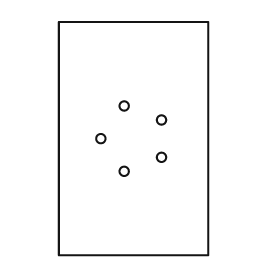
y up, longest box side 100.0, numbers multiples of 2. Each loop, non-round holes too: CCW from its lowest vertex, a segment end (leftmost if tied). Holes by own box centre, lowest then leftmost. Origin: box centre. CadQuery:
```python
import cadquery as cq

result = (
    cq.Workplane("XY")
    .moveTo(-32.0, -50.0)
    .lineTo(32.0, -50.0)
    .lineTo(32.0, 50.0)
    .lineTo(-32.0, 50.0)
    .close()
    .moveTo(-4.0, -14.0)
    .circle(2.0)
    .moveTo(12.0, -8.0)
    .circle(2.0)
    .moveTo(-14.0, 0.0)
    .circle(2.0)
    .moveTo(12.0, 8.0)
    .circle(2.0)
    .moveTo(-4.0, 14.0)
    .circle(2.0)
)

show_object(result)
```